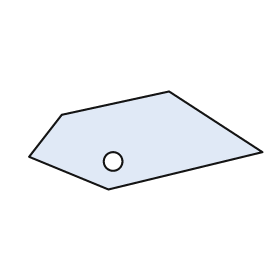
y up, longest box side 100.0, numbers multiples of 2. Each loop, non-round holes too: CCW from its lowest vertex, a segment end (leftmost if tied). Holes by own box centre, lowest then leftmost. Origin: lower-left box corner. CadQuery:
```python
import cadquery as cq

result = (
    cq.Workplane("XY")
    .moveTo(34.0, 0.0)
    .lineTo(100.0, 16.0)
    .lineTo(60.0, 42.0)
    .lineTo(14.0, 32.0)
    .lineTo(0.0, 14.0)
    .close()
    .moveTo(36.0, 12.0)
    .circle(4.0)
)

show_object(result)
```